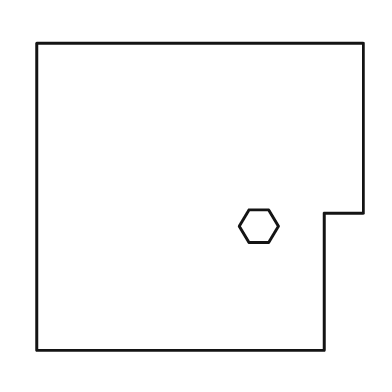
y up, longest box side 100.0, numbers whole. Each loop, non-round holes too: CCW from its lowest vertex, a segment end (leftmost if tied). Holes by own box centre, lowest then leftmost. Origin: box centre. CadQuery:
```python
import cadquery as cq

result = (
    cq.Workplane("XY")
    .moveTo(-50.0, -47.0)
    .lineTo(38.0, -47.0)
    .lineTo(38.0, -5.0)
    .lineTo(50.0, -5.0)
    .lineTo(50.0, 47.0)
    .lineTo(-50.0, 47.0)
    .close()
    .moveTo(15.0, -14.0)
    .lineTo(21.0, -14.0)
    .lineTo(24.0, -9.0)
    .lineTo(21.0, -4.0)
    .lineTo(15.0, -4.0)
    .lineTo(12.0, -9.0)
    .close()
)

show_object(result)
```